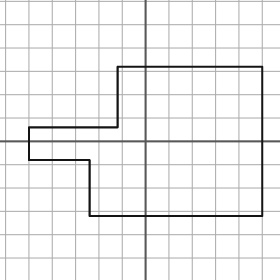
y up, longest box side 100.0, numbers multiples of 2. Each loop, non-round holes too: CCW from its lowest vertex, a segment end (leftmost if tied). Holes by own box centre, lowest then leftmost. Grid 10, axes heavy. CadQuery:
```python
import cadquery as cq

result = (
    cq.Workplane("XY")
    .moveTo(-24.0, -32.0)
    .lineTo(50.0, -32.0)
    .lineTo(50.0, 32.0)
    .lineTo(-12.0, 32.0)
    .lineTo(-12.0, 6.0)
    .lineTo(-50.0, 6.0)
    .lineTo(-50.0, -8.0)
    .lineTo(-24.0, -8.0)
    .close()
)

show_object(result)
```